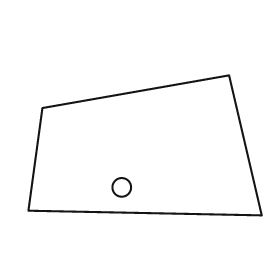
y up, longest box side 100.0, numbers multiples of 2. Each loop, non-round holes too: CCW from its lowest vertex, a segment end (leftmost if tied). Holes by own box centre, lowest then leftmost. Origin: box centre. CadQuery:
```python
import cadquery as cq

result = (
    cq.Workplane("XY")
    .moveTo(50.0, -30.0)
    .lineTo(36.0, 30.0)
    .lineTo(-44.0, 16.0)
    .lineTo(-50.0, -28.0)
    .close()
    .moveTo(-10.0, -18.0)
    .circle(4.0)
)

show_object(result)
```